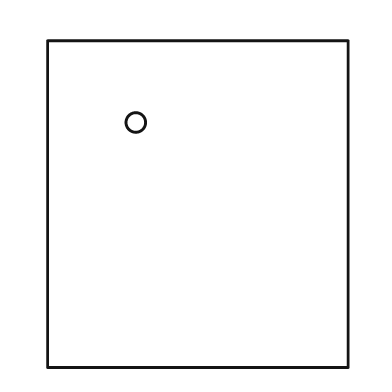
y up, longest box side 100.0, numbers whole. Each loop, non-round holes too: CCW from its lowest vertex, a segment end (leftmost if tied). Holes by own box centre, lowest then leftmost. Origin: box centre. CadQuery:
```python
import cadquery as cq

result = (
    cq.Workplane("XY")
    .moveTo(-46.0, -50.0)
    .lineTo(46.0, -50.0)
    .lineTo(46.0, 50.0)
    .lineTo(-46.0, 50.0)
    .close()
    .moveTo(-19.0, 25.0)
    .circle(3.0)
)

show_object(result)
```